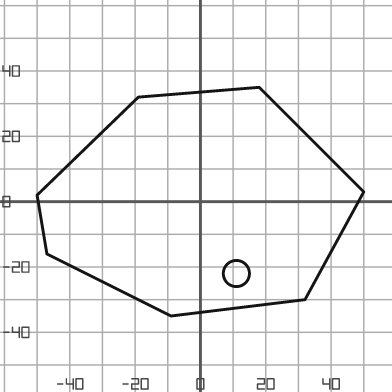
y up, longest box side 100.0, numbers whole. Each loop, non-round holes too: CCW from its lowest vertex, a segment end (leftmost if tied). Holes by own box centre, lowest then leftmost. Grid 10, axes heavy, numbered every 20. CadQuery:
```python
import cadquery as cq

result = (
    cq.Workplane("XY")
    .moveTo(-9.0, -35.0)
    .lineTo(32.0, -30.0)
    .lineTo(50.0, 3.0)
    .lineTo(18.0, 35.0)
    .lineTo(-19.0, 32.0)
    .lineTo(-50.0, 2.0)
    .lineTo(-47.0, -16.0)
    .close()
    .moveTo(11.0, -22.0)
    .circle(4.0)
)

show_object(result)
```